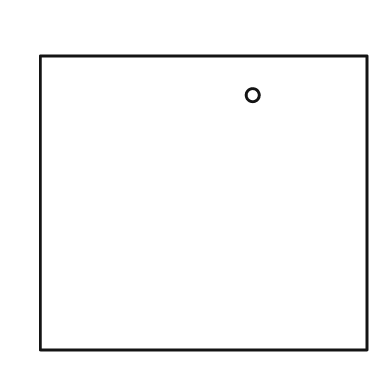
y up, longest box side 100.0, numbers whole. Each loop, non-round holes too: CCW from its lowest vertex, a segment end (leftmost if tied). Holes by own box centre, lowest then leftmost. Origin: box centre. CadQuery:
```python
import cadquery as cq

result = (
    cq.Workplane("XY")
    .moveTo(-50.0, -45.0)
    .lineTo(50.0, -45.0)
    .lineTo(50.0, 45.0)
    .lineTo(-50.0, 45.0)
    .close()
    .moveTo(15.0, 33.0)
    .circle(2.0)
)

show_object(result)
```